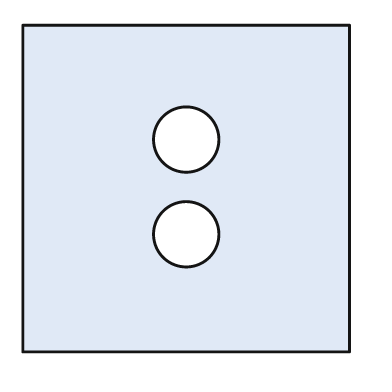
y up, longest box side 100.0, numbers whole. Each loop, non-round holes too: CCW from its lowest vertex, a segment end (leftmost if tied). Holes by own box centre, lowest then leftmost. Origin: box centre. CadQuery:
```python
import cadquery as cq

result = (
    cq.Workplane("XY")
    .moveTo(-50.0, -50.0)
    .lineTo(50.0, -50.0)
    .lineTo(50.0, 50.0)
    .lineTo(-50.0, 50.0)
    .close()
    .moveTo(0.0, -14.0)
    .circle(10.0)
    .moveTo(0.0, 15.0)
    .circle(10.0)
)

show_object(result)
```